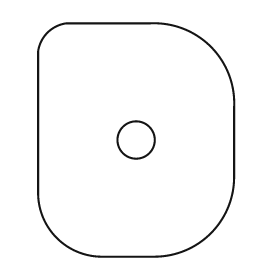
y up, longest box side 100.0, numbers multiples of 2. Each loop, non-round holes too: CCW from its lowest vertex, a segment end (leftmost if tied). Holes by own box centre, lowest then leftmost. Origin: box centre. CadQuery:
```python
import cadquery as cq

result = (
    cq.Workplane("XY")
    .moveTo(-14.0, -50.0)
    .lineTo(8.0, -50.0)
    .threePointArc((32.0, -40.0), (42.0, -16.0))
    .lineTo(42.0, 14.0)
    .threePointArc((32.0, 40.0), (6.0, 50.0))
    .lineTo(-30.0, 50.0)
    .threePointArc((-38.0, 46.0), (-42.0, 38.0))
    .lineTo(-42.0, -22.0)
    .threePointArc((-34.0, -42.0), (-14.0, -50.0))
    .close()
    .moveTo(0.0, 0.0)
    .circle(8.0)
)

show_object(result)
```